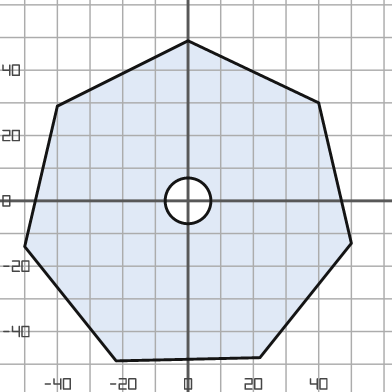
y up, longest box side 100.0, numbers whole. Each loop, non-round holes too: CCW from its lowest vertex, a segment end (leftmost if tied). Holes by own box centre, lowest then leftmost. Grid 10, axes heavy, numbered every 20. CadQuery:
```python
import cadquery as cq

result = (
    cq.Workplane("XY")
    .moveTo(-22.0, -49.0)
    .lineTo(22.0, -48.0)
    .lineTo(50.0, -13.0)
    .lineTo(40.0, 30.0)
    .lineTo(0.0, 49.0)
    .lineTo(-40.0, 29.0)
    .lineTo(-50.0, -14.0)
    .close()
    .moveTo(0.0, 0.0)
    .circle(7.0)
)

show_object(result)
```